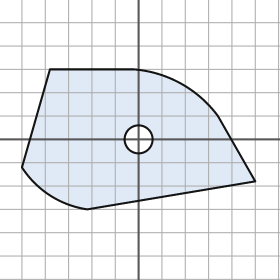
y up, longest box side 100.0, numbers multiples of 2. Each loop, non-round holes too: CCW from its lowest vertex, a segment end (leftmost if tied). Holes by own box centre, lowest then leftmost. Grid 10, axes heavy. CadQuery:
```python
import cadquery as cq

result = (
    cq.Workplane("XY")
    .moveTo(-22.0, -30.0)
    .lineTo(50.0, -18.0)
    .lineTo(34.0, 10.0)
    .threePointArc((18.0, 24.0), (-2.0, 30.0))
    .lineTo(-38.0, 30.0)
    .lineTo(-50.0, -12.0)
    .threePointArc((-38.0, -24.0), (-22.0, -30.0))
    .close()
    .moveTo(0.0, 0.0)
    .circle(6.0)
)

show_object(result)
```